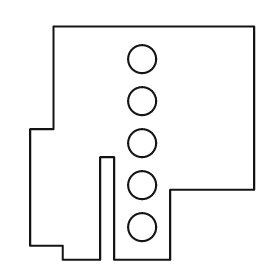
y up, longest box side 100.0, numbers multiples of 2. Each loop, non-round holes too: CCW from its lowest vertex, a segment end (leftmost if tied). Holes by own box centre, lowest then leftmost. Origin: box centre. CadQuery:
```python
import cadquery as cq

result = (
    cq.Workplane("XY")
    .moveTo(-34.0, -50.0)
    .lineTo(-18.0, -50.0)
    .lineTo(-18.0, -6.0)
    .lineTo(-12.0, -6.0)
    .lineTo(-12.0, -50.0)
    .lineTo(12.0, -50.0)
    .lineTo(12.0, -20.0)
    .lineTo(48.0, -20.0)
    .lineTo(48.0, 50.0)
    .lineTo(-38.0, 50.0)
    .lineTo(-38.0, 6.0)
    .lineTo(-48.0, 6.0)
    .lineTo(-48.0, -44.0)
    .lineTo(-34.0, -44.0)
    .close()
    .moveTo(0.0, -36.0)
    .circle(6.0)
    .moveTo(0.0, -18.0)
    .circle(6.0)
    .moveTo(0.0, 0.0)
    .circle(6.0)
    .moveTo(0.0, 18.0)
    .circle(6.0)
    .moveTo(0.0, 36.0)
    .circle(6.0)
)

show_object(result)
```